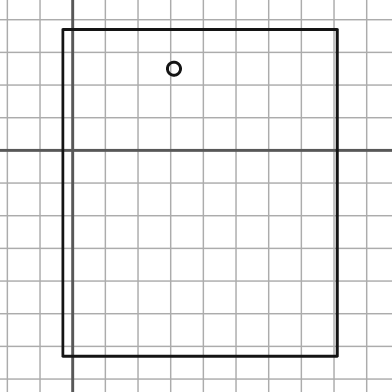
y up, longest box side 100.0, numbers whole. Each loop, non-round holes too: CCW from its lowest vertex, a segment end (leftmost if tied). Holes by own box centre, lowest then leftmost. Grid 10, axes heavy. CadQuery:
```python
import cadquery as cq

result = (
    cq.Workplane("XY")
    .moveTo(-3.0, -63.0)
    .lineTo(81.0, -63.0)
    .lineTo(81.0, 37.0)
    .lineTo(-3.0, 37.0)
    .close()
    .moveTo(31.0, 25.0)
    .circle(2.0)
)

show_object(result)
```